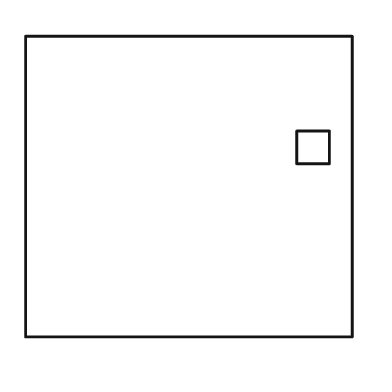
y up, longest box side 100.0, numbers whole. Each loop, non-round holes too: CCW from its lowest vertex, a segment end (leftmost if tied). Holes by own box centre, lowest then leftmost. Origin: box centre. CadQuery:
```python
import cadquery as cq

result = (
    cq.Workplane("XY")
    .moveTo(-50.0, -46.0)
    .lineTo(50.0, -46.0)
    .lineTo(50.0, 46.0)
    .lineTo(-50.0, 46.0)
    .close()
    .moveTo(33.0, 7.0)
    .lineTo(43.0, 7.0)
    .lineTo(43.0, 17.0)
    .lineTo(33.0, 17.0)
    .close()
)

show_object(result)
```